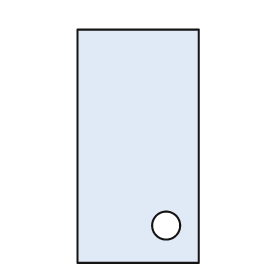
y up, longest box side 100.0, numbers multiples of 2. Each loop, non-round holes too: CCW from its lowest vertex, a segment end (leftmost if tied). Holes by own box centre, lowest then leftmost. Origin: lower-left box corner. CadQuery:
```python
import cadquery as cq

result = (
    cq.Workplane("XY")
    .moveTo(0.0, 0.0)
    .lineTo(52.0, 0.0)
    .lineTo(52.0, 100.0)
    .lineTo(0.0, 100.0)
    .close()
    .moveTo(38.0, 16.0)
    .circle(6.0)
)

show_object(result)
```